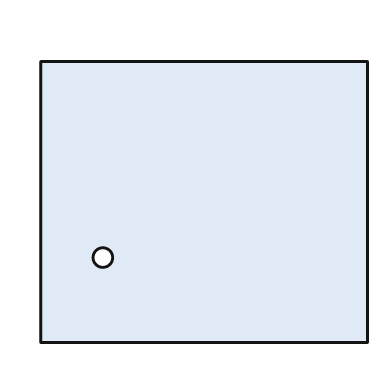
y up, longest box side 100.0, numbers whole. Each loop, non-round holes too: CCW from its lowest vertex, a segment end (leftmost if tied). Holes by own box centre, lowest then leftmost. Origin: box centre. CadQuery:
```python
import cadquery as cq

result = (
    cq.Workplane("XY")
    .moveTo(-50.0, -43.0)
    .lineTo(50.0, -43.0)
    .lineTo(50.0, 43.0)
    .lineTo(-50.0, 43.0)
    .close()
    .moveTo(-31.0, -17.0)
    .circle(3.0)
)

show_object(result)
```